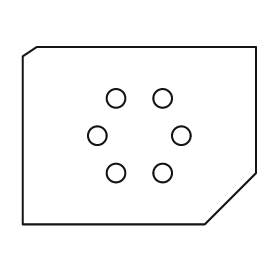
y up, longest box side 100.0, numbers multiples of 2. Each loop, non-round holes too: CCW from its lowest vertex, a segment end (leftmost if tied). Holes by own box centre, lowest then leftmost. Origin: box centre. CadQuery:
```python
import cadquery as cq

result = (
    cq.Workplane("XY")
    .moveTo(-50.0, -38.0)
    .lineTo(28.0, -38.0)
    .lineTo(50.0, -16.0)
    .lineTo(50.0, 38.0)
    .lineTo(-44.0, 38.0)
    .lineTo(-50.0, 34.0)
    .close()
    .moveTo(-10.0, -16.0)
    .circle(4.0)
    .moveTo(10.0, -16.0)
    .circle(4.0)
    .moveTo(-18.0, 0.0)
    .circle(4.0)
    .moveTo(18.0, 0.0)
    .circle(4.0)
    .moveTo(-10.0, 16.0)
    .circle(4.0)
    .moveTo(10.0, 16.0)
    .circle(4.0)
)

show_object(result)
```